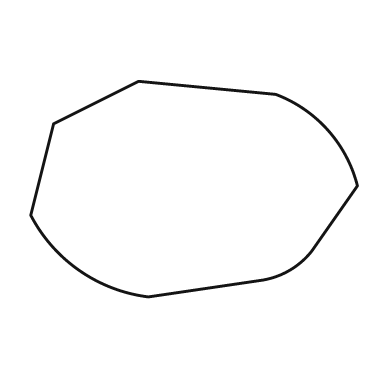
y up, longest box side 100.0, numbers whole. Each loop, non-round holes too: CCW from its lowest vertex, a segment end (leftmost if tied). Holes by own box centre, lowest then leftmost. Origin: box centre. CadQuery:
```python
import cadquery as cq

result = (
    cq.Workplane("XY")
    .moveTo(-14.0, -33.0)
    .lineTo(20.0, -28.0)
    .threePointArc((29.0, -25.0), (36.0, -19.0))
    .lineTo(50.0, 1.0)
    .threePointArc((41.0, 18.0), (25.0, 29.0))
    .lineTo(-17.0, 33.0)
    .lineTo(-43.0, 20.0)
    .lineTo(-50.0, -8.0)
    .threePointArc((-35.0, -25.0), (-14.0, -33.0))
    .close()
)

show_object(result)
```